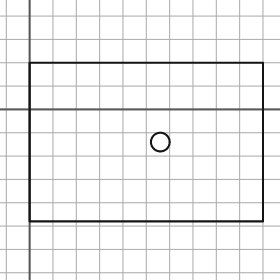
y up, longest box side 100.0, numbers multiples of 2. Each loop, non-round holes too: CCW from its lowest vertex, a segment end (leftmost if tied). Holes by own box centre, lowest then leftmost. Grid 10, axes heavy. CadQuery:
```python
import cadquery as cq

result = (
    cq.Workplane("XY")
    .moveTo(0.0, -48.0)
    .lineTo(100.0, -48.0)
    .lineTo(100.0, 20.0)
    .lineTo(0.0, 20.0)
    .close()
    .moveTo(56.0, -14.0)
    .circle(4.0)
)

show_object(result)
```